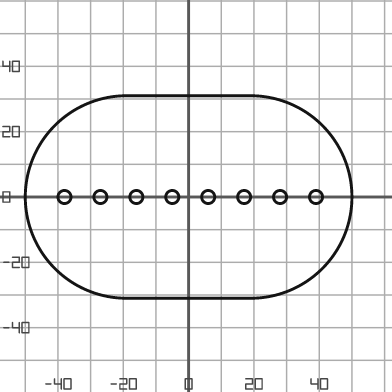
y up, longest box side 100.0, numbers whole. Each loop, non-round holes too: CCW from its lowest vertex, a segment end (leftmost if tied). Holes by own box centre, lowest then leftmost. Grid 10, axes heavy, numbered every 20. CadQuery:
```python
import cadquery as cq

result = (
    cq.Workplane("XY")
    .moveTo(-19.0, -31.0)
    .lineTo(19.0, -31.0)
    .threePointArc((50.0, 0.0), (19.0, 31.0))
    .lineTo(-19.0, 31.0)
    .threePointArc((-50.0, 0.0), (-19.0, -31.0))
    .close()
    .moveTo(-38.0, 0.0)
    .circle(2.0)
    .moveTo(-27.0, 0.0)
    .circle(2.0)
    .moveTo(-16.0, 0.0)
    .circle(2.0)
    .moveTo(-5.0, 0.0)
    .circle(2.0)
    .moveTo(6.0, 0.0)
    .circle(2.0)
    .moveTo(17.0, 0.0)
    .circle(2.0)
    .moveTo(28.0, 0.0)
    .circle(2.0)
    .moveTo(39.0, 0.0)
    .circle(2.0)
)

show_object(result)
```